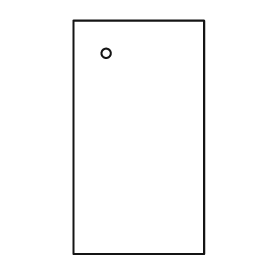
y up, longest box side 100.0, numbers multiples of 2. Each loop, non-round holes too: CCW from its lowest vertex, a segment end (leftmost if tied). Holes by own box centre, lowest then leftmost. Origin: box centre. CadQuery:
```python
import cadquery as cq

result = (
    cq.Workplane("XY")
    .moveTo(-28.0, -50.0)
    .lineTo(28.0, -50.0)
    .lineTo(28.0, 50.0)
    .lineTo(-28.0, 50.0)
    .close()
    .moveTo(-14.0, 36.0)
    .circle(2.0)
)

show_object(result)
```